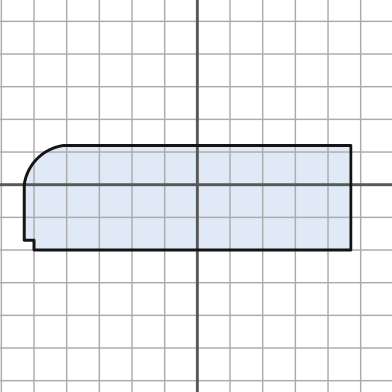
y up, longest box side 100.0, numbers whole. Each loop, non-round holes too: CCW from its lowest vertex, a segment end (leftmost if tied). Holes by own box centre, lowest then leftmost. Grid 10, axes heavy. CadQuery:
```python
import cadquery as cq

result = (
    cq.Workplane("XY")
    .moveTo(-50.0, -20.0)
    .lineTo(47.0, -20.0)
    .lineTo(47.0, 12.0)
    .lineTo(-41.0, 12.0)
    .threePointArc((-49.0, 8.0), (-53.0, 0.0))
    .lineTo(-53.0, -17.0)
    .lineTo(-50.0, -17.0)
    .close()
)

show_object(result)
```